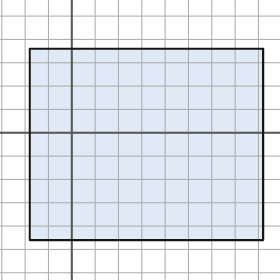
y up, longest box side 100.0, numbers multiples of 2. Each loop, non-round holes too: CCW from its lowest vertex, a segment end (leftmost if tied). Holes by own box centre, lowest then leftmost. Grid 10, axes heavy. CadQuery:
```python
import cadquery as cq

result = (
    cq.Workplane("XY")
    .moveTo(-18.0, -46.0)
    .lineTo(82.0, -46.0)
    .lineTo(82.0, 36.0)
    .lineTo(-18.0, 36.0)
    .close()
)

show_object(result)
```